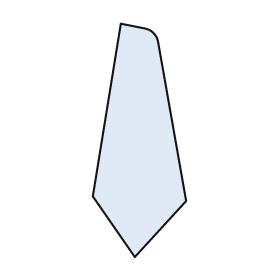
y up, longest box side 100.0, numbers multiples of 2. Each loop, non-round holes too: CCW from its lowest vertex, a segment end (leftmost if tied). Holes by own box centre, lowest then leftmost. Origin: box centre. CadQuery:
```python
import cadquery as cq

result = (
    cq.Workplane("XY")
    .moveTo(-2.0, -50.0)
    .lineTo(20.0, -26.0)
    .lineTo(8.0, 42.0)
    .threePointArc((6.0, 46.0), (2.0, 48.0))
    .lineTo(-8.0, 50.0)
    .lineTo(-20.0, -24.0)
    .close()
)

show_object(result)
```